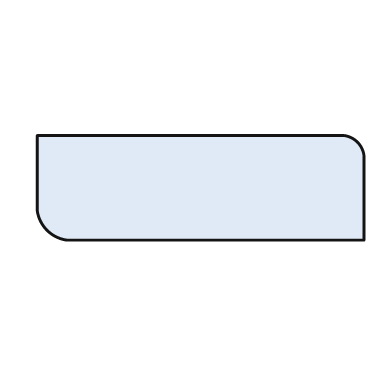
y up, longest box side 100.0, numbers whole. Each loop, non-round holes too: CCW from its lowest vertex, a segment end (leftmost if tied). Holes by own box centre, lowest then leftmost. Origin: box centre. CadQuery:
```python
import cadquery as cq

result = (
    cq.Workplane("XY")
    .moveTo(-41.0, -16.0)
    .lineTo(50.0, -16.0)
    .lineTo(50.0, 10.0)
    .threePointArc((48.0, 14.0), (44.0, 16.0))
    .lineTo(-50.0, 16.0)
    .lineTo(-50.0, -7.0)
    .threePointArc((-47.0, -13.0), (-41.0, -16.0))
    .close()
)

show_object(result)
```